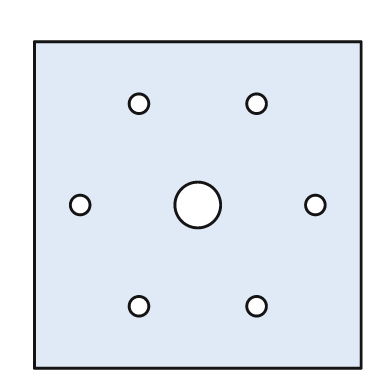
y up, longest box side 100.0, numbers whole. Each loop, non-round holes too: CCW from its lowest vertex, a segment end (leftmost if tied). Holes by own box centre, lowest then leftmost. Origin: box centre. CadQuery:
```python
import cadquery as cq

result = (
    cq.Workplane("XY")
    .moveTo(-50.0, -50.0)
    .lineTo(50.0, -50.0)
    .lineTo(50.0, 50.0)
    .lineTo(-50.0, 50.0)
    .close()
    .moveTo(-18.0, -31.0)
    .circle(3.0)
    .moveTo(18.0, -31.0)
    .circle(3.0)
    .moveTo(-36.0, 0.0)
    .circle(3.0)
    .moveTo(0.0, 0.0)
    .circle(7.0)
    .moveTo(36.0, 0.0)
    .circle(3.0)
    .moveTo(-18.0, 31.0)
    .circle(3.0)
    .moveTo(18.0, 31.0)
    .circle(3.0)
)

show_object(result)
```